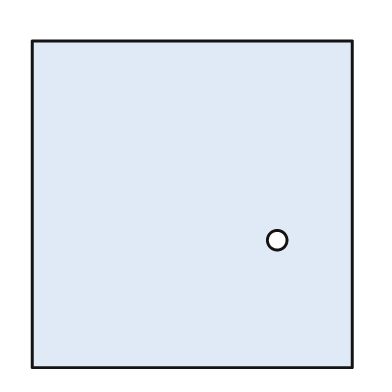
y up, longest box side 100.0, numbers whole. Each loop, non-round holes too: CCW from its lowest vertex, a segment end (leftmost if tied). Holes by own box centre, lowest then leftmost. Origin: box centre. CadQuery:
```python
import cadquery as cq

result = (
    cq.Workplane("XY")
    .moveTo(-49.0, -50.0)
    .lineTo(49.0, -50.0)
    .lineTo(49.0, 50.0)
    .lineTo(-49.0, 50.0)
    .close()
    .moveTo(26.0, -11.0)
    .circle(3.0)
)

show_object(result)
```